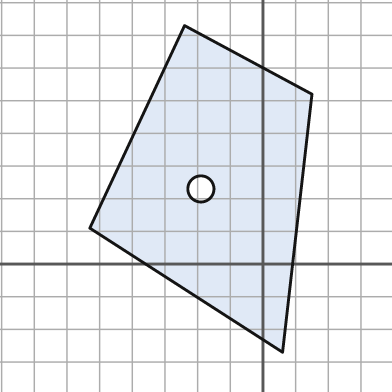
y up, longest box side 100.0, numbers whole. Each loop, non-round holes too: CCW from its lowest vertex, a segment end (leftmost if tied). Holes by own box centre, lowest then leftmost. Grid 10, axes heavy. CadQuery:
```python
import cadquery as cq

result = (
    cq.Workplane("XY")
    .moveTo(6.0, -27.0)
    .lineTo(15.0, 52.0)
    .lineTo(-24.0, 73.0)
    .lineTo(-53.0, 11.0)
    .close()
    .moveTo(-19.0, 23.0)
    .circle(4.0)
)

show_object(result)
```